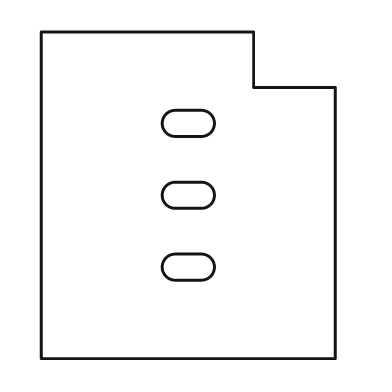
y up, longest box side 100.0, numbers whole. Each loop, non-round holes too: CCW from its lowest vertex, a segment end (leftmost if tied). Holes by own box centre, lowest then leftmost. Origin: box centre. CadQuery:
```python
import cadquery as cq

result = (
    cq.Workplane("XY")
    .moveTo(-45.0, -50.0)
    .lineTo(45.0, -50.0)
    .lineTo(45.0, 33.0)
    .lineTo(20.0, 33.0)
    .lineTo(20.0, 50.0)
    .lineTo(-45.0, 50.0)
    .close()
    .moveTo(-4.0, -26.0)
    .lineTo(4.0, -26.0)
    .threePointArc((8.0, -22.0), (4.0, -18.0))
    .lineTo(-4.0, -18.0)
    .threePointArc((-8.0, -22.0), (-4.0, -26.0))
    .close()
    .moveTo(-4.0, -4.0)
    .lineTo(4.0, -4.0)
    .threePointArc((8.0, 0.0), (4.0, 4.0))
    .lineTo(-4.0, 4.0)
    .threePointArc((-8.0, 0.0), (-4.0, -4.0))
    .close()
    .moveTo(-4.0, 18.0)
    .lineTo(4.0, 18.0)
    .threePointArc((8.0, 22.0), (4.0, 26.0))
    .lineTo(-4.0, 26.0)
    .threePointArc((-8.0, 22.0), (-4.0, 18.0))
    .close()
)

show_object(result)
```